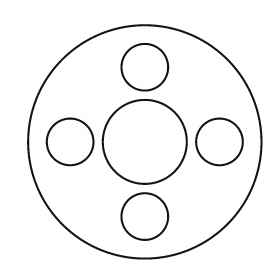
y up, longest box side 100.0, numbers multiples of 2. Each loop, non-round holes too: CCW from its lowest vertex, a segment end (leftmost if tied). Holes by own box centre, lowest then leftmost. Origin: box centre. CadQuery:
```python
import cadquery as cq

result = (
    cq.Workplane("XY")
    .moveTo(0.0, 0.0)
    .circle(50.0)
    .moveTo(0.0, -32.0)
    .circle(10.0)
    .moveTo(-32.0, 0.0)
    .circle(10.0)
    .moveTo(0.0, 0.0)
    .circle(18.0)
    .moveTo(32.0, 0.0)
    .circle(10.0)
    .moveTo(0.0, 32.0)
    .circle(10.0)
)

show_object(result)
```